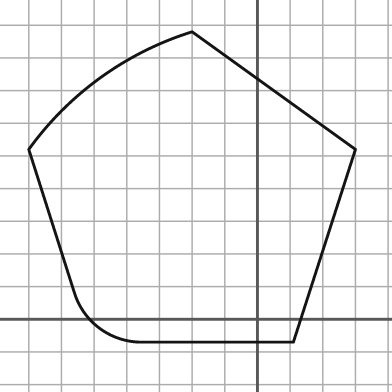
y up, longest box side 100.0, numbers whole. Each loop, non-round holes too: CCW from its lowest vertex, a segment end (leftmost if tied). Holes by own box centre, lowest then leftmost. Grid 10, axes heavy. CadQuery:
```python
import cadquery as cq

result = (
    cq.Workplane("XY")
    .moveTo(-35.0, -7.0)
    .lineTo(11.0, -7.0)
    .lineTo(30.0, 52.0)
    .lineTo(-20.0, 88.0)
    .threePointArc((-48.0, 74.0), (-70.0, 52.0))
    .lineTo(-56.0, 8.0)
    .threePointArc((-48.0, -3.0), (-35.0, -7.0))
    .close()
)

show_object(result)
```